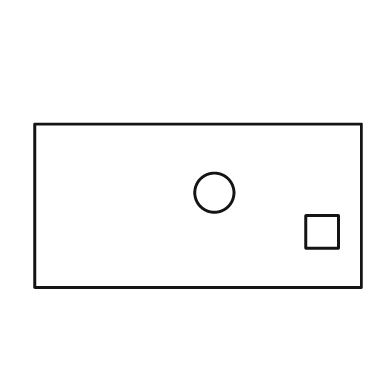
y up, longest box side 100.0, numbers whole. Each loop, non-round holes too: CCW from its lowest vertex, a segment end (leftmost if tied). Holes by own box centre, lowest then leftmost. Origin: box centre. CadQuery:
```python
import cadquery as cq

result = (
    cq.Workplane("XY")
    .moveTo(-50.0, -25.0)
    .lineTo(50.0, -25.0)
    .lineTo(50.0, 25.0)
    .lineTo(-50.0, 25.0)
    .close()
    .moveTo(33.0, -13.0)
    .lineTo(43.0, -13.0)
    .lineTo(43.0, -3.0)
    .lineTo(33.0, -3.0)
    .close()
    .moveTo(5.0, 4.0)
    .circle(6.0)
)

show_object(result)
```